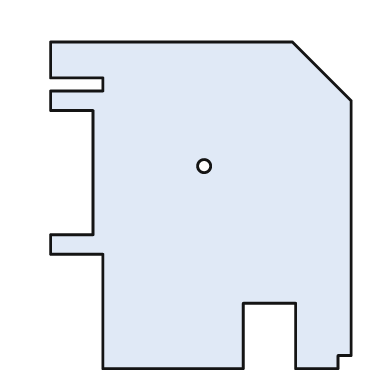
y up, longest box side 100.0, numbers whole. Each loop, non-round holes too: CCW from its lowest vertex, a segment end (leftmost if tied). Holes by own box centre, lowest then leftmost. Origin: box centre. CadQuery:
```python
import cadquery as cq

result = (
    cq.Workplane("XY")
    .moveTo(-30.0, -50.0)
    .lineTo(13.0, -50.0)
    .lineTo(13.0, -30.0)
    .lineTo(29.0, -30.0)
    .lineTo(29.0, -50.0)
    .lineTo(42.0, -50.0)
    .lineTo(42.0, -46.0)
    .lineTo(46.0, -46.0)
    .lineTo(46.0, 32.0)
    .lineTo(28.0, 50.0)
    .lineTo(-46.0, 50.0)
    .lineTo(-46.0, 39.0)
    .lineTo(-30.0, 39.0)
    .lineTo(-30.0, 35.0)
    .lineTo(-46.0, 35.0)
    .lineTo(-46.0, 29.0)
    .lineTo(-33.0, 29.0)
    .lineTo(-33.0, -9.0)
    .lineTo(-46.0, -9.0)
    .lineTo(-46.0, -15.0)
    .lineTo(-30.0, -15.0)
    .close()
    .moveTo(1.0, 12.0)
    .circle(2.0)
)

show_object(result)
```